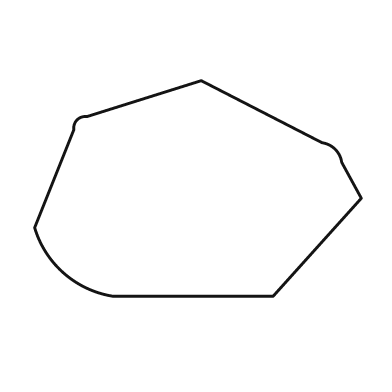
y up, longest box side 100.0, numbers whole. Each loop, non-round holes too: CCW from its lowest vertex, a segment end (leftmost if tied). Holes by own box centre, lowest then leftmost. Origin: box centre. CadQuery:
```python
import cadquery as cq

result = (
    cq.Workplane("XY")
    .moveTo(-26.0, -33.0)
    .lineTo(23.0, -33.0)
    .lineTo(50.0, -3.0)
    .lineTo(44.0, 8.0)
    .threePointArc((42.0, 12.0), (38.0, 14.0))
    .lineTo(1.0, 33.0)
    .lineTo(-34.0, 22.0)
    .threePointArc((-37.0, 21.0), (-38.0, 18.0))
    .lineTo(-50.0, -12.0)
    .threePointArc((-41.0, -26.0), (-26.0, -33.0))
    .close()
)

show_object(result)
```